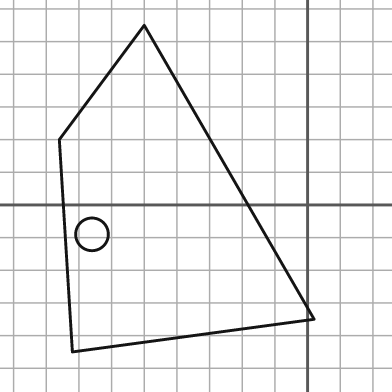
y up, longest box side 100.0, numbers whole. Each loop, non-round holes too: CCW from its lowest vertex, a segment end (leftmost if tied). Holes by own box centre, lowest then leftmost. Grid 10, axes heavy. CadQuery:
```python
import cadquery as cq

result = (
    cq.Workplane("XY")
    .moveTo(-72.0, -45.0)
    .lineTo(2.0, -35.0)
    .lineTo(-50.0, 55.0)
    .lineTo(-76.0, 20.0)
    .close()
    .moveTo(-66.0, -9.0)
    .circle(5.0)
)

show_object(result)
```